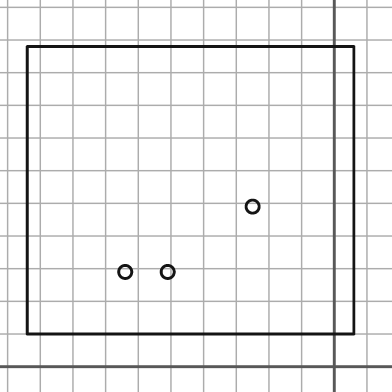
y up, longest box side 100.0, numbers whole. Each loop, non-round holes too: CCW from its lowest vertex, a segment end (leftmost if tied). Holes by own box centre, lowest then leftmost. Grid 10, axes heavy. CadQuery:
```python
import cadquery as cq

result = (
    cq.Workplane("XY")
    .moveTo(-94.0, 10.0)
    .lineTo(6.0, 10.0)
    .lineTo(6.0, 98.0)
    .lineTo(-94.0, 98.0)
    .close()
    .moveTo(-64.0, 29.0)
    .circle(2.0)
    .moveTo(-51.0, 29.0)
    .circle(2.0)
    .moveTo(-25.0, 49.0)
    .circle(2.0)
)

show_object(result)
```